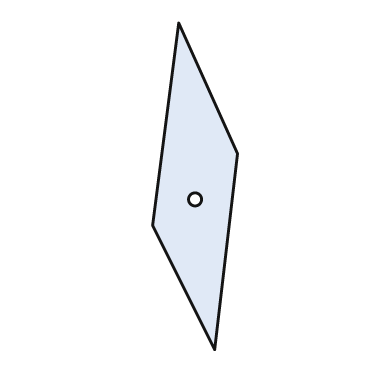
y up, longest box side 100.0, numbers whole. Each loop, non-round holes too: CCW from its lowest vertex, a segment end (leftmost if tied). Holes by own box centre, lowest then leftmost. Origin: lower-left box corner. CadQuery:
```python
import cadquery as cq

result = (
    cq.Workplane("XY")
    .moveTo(19.0, 0.0)
    .lineTo(26.0, 60.0)
    .lineTo(8.0, 100.0)
    .lineTo(0.0, 38.0)
    .close()
    .moveTo(13.0, 46.0)
    .circle(2.0)
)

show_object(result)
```